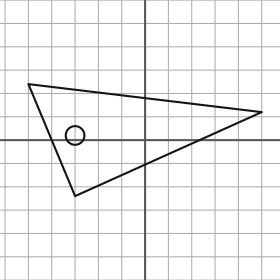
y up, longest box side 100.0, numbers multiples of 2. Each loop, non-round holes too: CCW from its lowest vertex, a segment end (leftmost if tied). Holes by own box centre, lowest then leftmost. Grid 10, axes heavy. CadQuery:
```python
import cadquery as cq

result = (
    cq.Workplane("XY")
    .moveTo(-30.0, -24.0)
    .lineTo(50.0, 12.0)
    .lineTo(-50.0, 24.0)
    .close()
    .moveTo(-30.0, 2.0)
    .circle(4.0)
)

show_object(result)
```